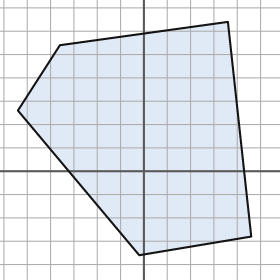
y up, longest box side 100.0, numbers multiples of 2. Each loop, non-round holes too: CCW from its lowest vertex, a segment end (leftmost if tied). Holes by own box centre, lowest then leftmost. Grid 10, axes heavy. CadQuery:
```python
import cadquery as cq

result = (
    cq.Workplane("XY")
    .moveTo(-2.0, -36.0)
    .lineTo(46.0, -28.0)
    .lineTo(36.0, 64.0)
    .lineTo(-36.0, 54.0)
    .lineTo(-54.0, 26.0)
    .close()
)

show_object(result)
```